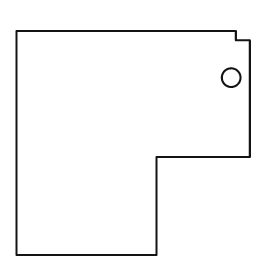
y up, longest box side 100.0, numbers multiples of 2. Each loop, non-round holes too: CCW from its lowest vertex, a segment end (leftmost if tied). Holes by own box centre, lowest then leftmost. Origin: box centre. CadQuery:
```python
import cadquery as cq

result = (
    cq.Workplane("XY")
    .moveTo(-50.0, -48.0)
    .lineTo(10.0, -48.0)
    .lineTo(10.0, -6.0)
    .lineTo(50.0, -6.0)
    .lineTo(50.0, 44.0)
    .lineTo(44.0, 44.0)
    .lineTo(44.0, 48.0)
    .lineTo(-50.0, 48.0)
    .close()
    .moveTo(42.0, 28.0)
    .circle(4.0)
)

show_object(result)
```